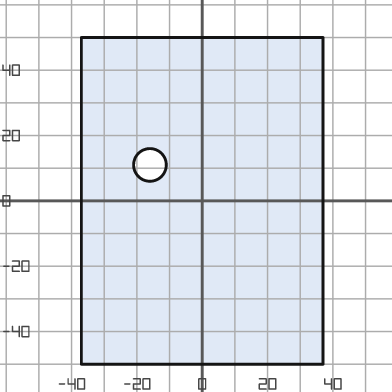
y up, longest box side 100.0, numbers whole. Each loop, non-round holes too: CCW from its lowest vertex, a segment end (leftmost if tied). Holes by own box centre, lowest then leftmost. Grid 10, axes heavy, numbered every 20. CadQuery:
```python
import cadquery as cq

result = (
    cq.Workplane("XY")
    .moveTo(-37.0, -50.0)
    .lineTo(37.0, -50.0)
    .lineTo(37.0, 50.0)
    .lineTo(-37.0, 50.0)
    .close()
    .moveTo(-16.0, 11.0)
    .circle(5.0)
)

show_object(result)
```